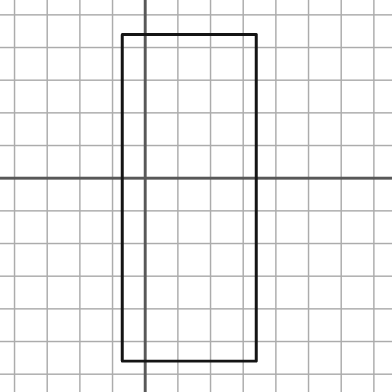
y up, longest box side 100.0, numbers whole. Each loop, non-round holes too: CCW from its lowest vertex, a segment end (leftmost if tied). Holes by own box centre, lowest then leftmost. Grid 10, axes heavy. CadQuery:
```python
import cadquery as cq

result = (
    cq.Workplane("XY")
    .moveTo(-7.0, -56.0)
    .lineTo(34.0, -56.0)
    .lineTo(34.0, 44.0)
    .lineTo(-7.0, 44.0)
    .close()
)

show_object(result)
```